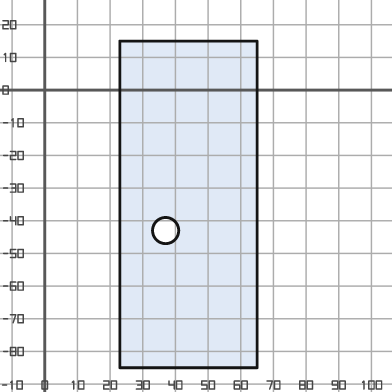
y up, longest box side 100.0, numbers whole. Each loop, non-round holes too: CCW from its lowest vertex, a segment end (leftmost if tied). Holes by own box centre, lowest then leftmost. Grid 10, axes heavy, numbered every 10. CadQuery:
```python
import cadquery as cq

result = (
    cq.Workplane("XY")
    .moveTo(23.0, -85.0)
    .lineTo(65.0, -85.0)
    .lineTo(65.0, 15.0)
    .lineTo(23.0, 15.0)
    .close()
    .moveTo(37.0, -43.0)
    .circle(4.0)
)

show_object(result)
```